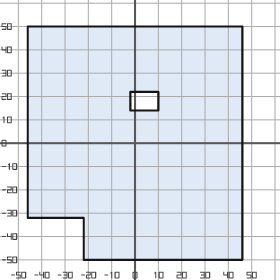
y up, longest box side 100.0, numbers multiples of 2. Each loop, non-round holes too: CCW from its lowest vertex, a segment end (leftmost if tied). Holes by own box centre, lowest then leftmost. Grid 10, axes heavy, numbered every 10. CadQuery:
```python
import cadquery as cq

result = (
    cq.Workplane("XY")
    .moveTo(-22.0, -50.0)
    .lineTo(46.0, -50.0)
    .lineTo(46.0, 50.0)
    .lineTo(-46.0, 50.0)
    .lineTo(-46.0, -32.0)
    .lineTo(-22.0, -32.0)
    .close()
    .moveTo(-2.0, 14.0)
    .lineTo(10.0, 14.0)
    .lineTo(10.0, 22.0)
    .lineTo(-2.0, 22.0)
    .close()
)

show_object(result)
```